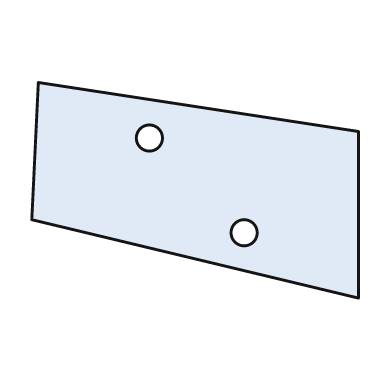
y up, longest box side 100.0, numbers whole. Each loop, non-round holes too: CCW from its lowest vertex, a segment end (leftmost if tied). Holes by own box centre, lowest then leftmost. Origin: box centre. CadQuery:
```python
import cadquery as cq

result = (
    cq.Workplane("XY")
    .moveTo(50.0, -33.0)
    .lineTo(50.0, 18.0)
    .lineTo(-48.0, 33.0)
    .lineTo(-50.0, -9.0)
    .close()
    .moveTo(15.0, -13.0)
    .circle(4.0)
    .moveTo(-14.0, 16.0)
    .circle(4.0)
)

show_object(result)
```